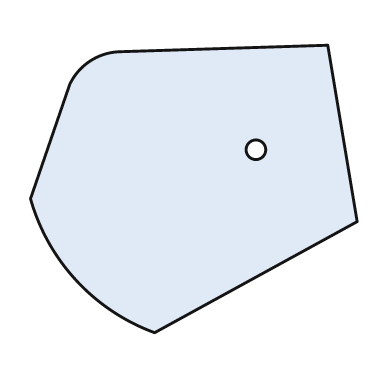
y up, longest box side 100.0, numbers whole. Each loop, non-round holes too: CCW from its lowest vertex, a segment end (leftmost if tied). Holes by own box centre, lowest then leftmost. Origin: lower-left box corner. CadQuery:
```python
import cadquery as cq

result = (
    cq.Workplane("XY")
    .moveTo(38.0, 0.0)
    .lineTo(100.0, 34.0)
    .lineTo(91.0, 88.0)
    .lineTo(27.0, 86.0)
    .threePointArc((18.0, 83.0), (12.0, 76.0))
    .lineTo(0.0, 41.0)
    .threePointArc((14.0, 16.0), (38.0, 0.0))
    .close()
    .moveTo(69.0, 56.0)
    .circle(3.0)
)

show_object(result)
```